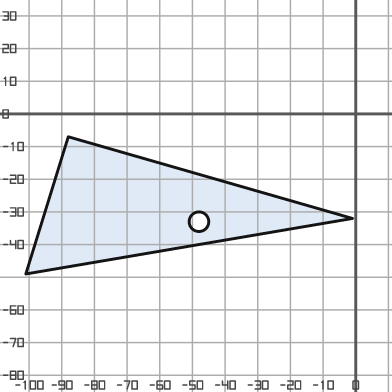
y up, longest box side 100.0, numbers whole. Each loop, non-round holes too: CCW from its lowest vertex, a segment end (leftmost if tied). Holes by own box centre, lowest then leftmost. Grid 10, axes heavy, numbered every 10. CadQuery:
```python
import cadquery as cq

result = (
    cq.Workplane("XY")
    .moveTo(-101.0, -49.0)
    .lineTo(-1.0, -32.0)
    .lineTo(-88.0, -7.0)
    .close()
    .moveTo(-48.0, -33.0)
    .circle(3.0)
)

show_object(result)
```